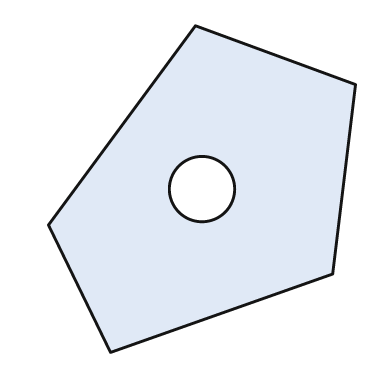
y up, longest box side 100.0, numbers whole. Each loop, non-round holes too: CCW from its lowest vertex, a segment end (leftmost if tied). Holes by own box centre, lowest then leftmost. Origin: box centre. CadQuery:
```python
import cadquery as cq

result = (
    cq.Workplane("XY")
    .moveTo(-28.0, -50.0)
    .lineTo(40.0, -26.0)
    .lineTo(47.0, 32.0)
    .lineTo(-2.0, 50.0)
    .lineTo(-47.0, -11.0)
    .close()
    .moveTo(0.0, 0.0)
    .circle(10.0)
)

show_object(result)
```